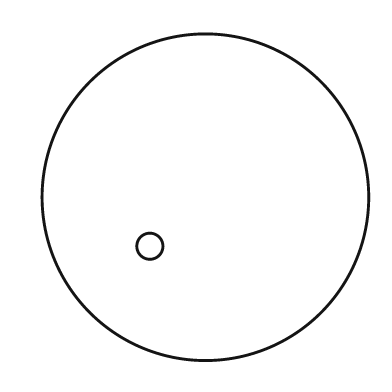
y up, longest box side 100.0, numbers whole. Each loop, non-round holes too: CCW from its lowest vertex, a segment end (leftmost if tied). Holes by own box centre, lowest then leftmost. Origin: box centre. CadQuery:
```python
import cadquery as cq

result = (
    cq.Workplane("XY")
    .moveTo(0.0, 0.0)
    .circle(50.0)
    .moveTo(-17.0, -15.0)
    .circle(4.0)
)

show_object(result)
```